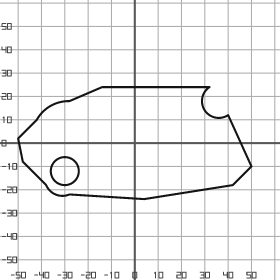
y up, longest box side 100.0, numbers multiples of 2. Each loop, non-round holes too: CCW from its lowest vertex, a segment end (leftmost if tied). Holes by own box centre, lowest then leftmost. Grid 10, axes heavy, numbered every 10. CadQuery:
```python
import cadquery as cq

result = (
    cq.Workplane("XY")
    .moveTo(4.0, -24.0)
    .lineTo(42.0, -18.0)
    .lineTo(50.0, -10.0)
    .lineTo(40.0, 12.0)
    .threePointArc((30.0, 14.0), (32.0, 24.0))
    .lineTo(-14.0, 24.0)
    .lineTo(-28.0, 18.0)
    .threePointArc((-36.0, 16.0), (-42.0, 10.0))
    .lineTo(-50.0, 2.0)
    .lineTo(-48.0, -8.0)
    .lineTo(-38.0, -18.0)
    .threePointArc((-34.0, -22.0), (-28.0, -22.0))
    .close()
    .moveTo(-30.0, -12.0)
    .circle(6.0)
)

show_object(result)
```